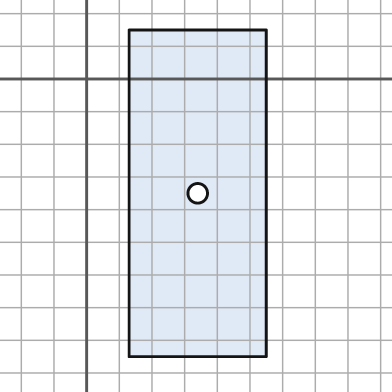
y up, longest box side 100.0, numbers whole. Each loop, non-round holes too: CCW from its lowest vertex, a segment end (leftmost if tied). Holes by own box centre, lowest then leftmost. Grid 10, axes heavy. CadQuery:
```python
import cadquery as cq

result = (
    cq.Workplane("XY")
    .moveTo(13.0, -85.0)
    .lineTo(55.0, -85.0)
    .lineTo(55.0, 15.0)
    .lineTo(13.0, 15.0)
    .close()
    .moveTo(34.0, -35.0)
    .circle(3.0)
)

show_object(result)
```